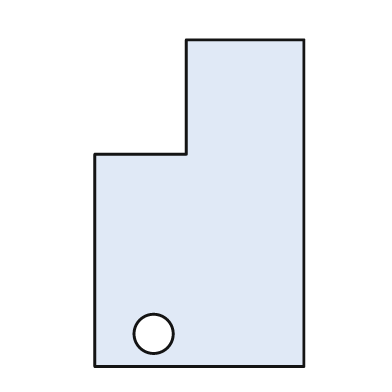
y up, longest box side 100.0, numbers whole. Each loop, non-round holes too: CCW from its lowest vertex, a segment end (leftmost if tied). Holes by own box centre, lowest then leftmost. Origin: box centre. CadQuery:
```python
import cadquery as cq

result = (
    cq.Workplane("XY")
    .moveTo(-32.0, -50.0)
    .lineTo(32.0, -50.0)
    .lineTo(32.0, 50.0)
    .lineTo(-4.0, 50.0)
    .lineTo(-4.0, 15.0)
    .lineTo(-32.0, 15.0)
    .close()
    .moveTo(-14.0, -40.0)
    .circle(6.0)
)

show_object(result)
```